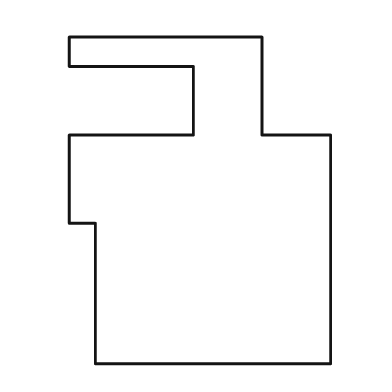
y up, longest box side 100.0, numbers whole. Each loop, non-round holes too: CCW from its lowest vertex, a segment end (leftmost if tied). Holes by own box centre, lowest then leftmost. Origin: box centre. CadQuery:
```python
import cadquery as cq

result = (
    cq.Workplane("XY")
    .moveTo(-32.0, -50.0)
    .lineTo(40.0, -50.0)
    .lineTo(40.0, 20.0)
    .lineTo(19.0, 20.0)
    .lineTo(19.0, 50.0)
    .lineTo(-40.0, 50.0)
    .lineTo(-40.0, 41.0)
    .lineTo(-2.0, 41.0)
    .lineTo(-2.0, 20.0)
    .lineTo(-40.0, 20.0)
    .lineTo(-40.0, -7.0)
    .lineTo(-32.0, -7.0)
    .close()
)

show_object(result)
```